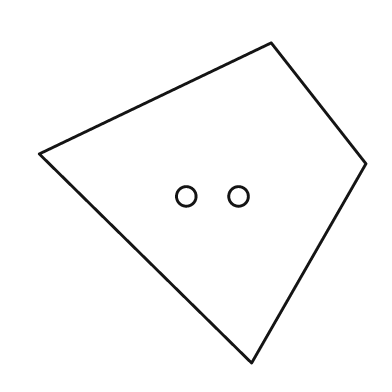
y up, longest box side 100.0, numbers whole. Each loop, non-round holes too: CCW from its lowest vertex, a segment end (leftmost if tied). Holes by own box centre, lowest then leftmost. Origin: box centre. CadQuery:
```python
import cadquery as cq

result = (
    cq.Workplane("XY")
    .moveTo(15.0, -49.0)
    .lineTo(50.0, 12.0)
    .lineTo(21.0, 49.0)
    .lineTo(-50.0, 15.0)
    .close()
    .moveTo(-5.0, 2.0)
    .circle(3.0)
    .moveTo(11.0, 2.0)
    .circle(3.0)
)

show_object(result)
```